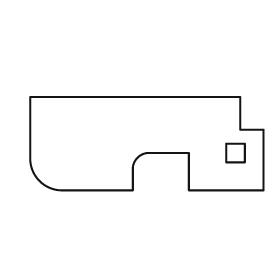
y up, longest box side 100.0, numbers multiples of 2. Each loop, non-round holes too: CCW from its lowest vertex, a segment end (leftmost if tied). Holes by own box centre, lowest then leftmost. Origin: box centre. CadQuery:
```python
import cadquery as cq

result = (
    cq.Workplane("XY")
    .moveTo(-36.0, -20.0)
    .lineTo(-6.0, -20.0)
    .lineTo(-6.0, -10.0)
    .threePointArc((-4.0, -6.0), (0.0, -4.0))
    .lineTo(18.0, -4.0)
    .lineTo(18.0, -20.0)
    .lineTo(50.0, -20.0)
    .lineTo(50.0, 6.0)
    .lineTo(40.0, 6.0)
    .lineTo(40.0, 20.0)
    .lineTo(-50.0, 20.0)
    .lineTo(-50.0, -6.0)
    .threePointArc((-46.0, -16.0), (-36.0, -20.0))
    .close()
    .moveTo(34.0, -8.0)
    .lineTo(42.0, -8.0)
    .lineTo(42.0, 0.0)
    .lineTo(34.0, 0.0)
    .close()
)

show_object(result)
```